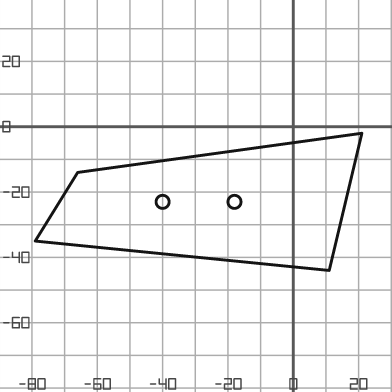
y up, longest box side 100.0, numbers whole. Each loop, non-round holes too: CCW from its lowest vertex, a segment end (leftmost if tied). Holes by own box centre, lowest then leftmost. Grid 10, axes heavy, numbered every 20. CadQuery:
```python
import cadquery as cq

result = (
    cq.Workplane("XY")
    .moveTo(11.0, -44.0)
    .lineTo(21.0, -2.0)
    .lineTo(-66.0, -14.0)
    .lineTo(-79.0, -35.0)
    .close()
    .moveTo(-40.0, -23.0)
    .circle(2.0)
    .moveTo(-18.0, -23.0)
    .circle(2.0)
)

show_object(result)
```